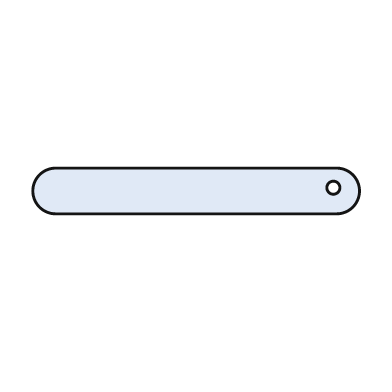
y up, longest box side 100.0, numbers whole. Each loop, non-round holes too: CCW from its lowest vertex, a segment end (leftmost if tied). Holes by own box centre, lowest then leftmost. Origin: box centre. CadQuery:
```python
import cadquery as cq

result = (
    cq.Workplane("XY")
    .moveTo(-43.0, -7.0)
    .lineTo(43.0, -7.0)
    .threePointArc((50.0, 0.0), (43.0, 7.0))
    .lineTo(-43.0, 7.0)
    .threePointArc((-50.0, 0.0), (-43.0, -7.0))
    .close()
    .moveTo(42.0, 1.0)
    .circle(2.0)
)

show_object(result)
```